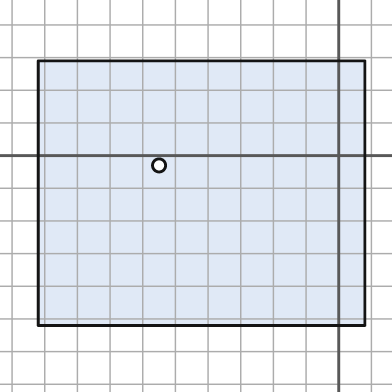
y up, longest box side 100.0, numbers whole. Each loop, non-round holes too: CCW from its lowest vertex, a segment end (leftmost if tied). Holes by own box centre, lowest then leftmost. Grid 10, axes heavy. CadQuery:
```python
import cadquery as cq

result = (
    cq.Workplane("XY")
    .moveTo(-92.0, -52.0)
    .lineTo(8.0, -52.0)
    .lineTo(8.0, 29.0)
    .lineTo(-92.0, 29.0)
    .close()
    .moveTo(-55.0, -3.0)
    .circle(2.0)
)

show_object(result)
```